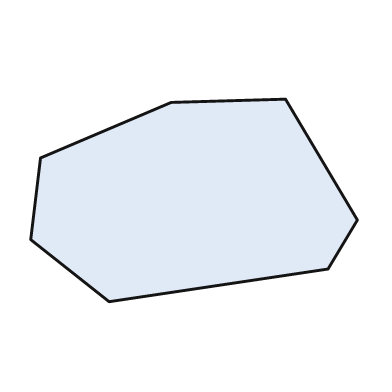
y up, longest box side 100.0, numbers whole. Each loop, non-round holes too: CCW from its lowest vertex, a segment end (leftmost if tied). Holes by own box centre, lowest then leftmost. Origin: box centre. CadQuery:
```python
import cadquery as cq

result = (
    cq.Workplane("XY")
    .moveTo(-26.0, -31.0)
    .lineTo(41.0, -21.0)
    .lineTo(50.0, -6.0)
    .lineTo(28.0, 31.0)
    .lineTo(-7.0, 30.0)
    .lineTo(-47.0, 13.0)
    .lineTo(-50.0, -12.0)
    .close()
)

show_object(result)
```